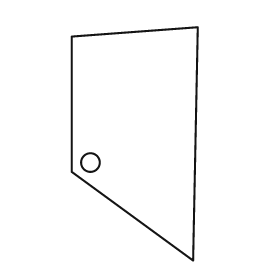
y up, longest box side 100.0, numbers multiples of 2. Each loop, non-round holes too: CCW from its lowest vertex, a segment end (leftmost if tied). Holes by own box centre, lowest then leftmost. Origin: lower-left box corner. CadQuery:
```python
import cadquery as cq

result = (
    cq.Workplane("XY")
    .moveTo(52.0, 0.0)
    .lineTo(54.0, 100.0)
    .lineTo(0.0, 96.0)
    .lineTo(0.0, 38.0)
    .close()
    .moveTo(8.0, 42.0)
    .circle(4.0)
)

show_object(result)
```